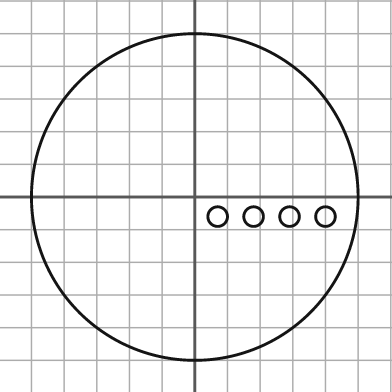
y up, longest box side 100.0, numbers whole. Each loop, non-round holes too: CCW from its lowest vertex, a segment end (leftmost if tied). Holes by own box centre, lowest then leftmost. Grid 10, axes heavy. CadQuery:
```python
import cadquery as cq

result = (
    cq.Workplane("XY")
    .moveTo(0.0, 0.0)
    .circle(50.0)
    .moveTo(7.0, -6.0)
    .circle(3.0)
    .moveTo(18.0, -6.0)
    .circle(3.0)
    .moveTo(29.0, -6.0)
    .circle(3.0)
    .moveTo(40.0, -6.0)
    .circle(3.0)
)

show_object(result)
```